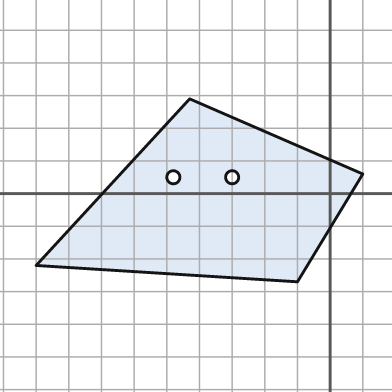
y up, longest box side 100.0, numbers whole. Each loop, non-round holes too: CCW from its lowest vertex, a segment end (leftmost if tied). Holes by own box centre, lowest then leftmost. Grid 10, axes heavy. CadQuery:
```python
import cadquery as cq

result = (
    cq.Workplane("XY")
    .moveTo(-10.0, -27.0)
    .lineTo(10.0, 6.0)
    .lineTo(-43.0, 29.0)
    .lineTo(-90.0, -22.0)
    .close()
    .moveTo(-48.0, 5.0)
    .circle(2.0)
    .moveTo(-30.0, 5.0)
    .circle(2.0)
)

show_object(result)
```